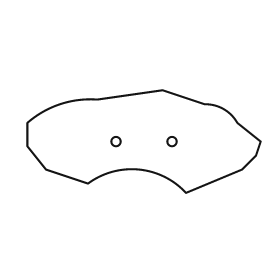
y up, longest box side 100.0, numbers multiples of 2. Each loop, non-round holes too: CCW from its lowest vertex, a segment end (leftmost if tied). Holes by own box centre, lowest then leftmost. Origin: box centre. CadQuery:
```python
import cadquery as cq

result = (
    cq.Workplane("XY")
    .moveTo(18.0, -22.0)
    .lineTo(42.0, -12.0)
    .lineTo(48.0, -6.0)
    .lineTo(50.0, 0.0)
    .lineTo(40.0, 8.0)
    .threePointArc((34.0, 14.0), (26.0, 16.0))
    .lineTo(8.0, 22.0)
    .lineTo(-20.0, 18.0)
    .threePointArc((-36.0, 16.0), (-50.0, 8.0))
    .lineTo(-50.0, -2.0)
    .lineTo(-42.0, -12.0)
    .lineTo(-24.0, -18.0)
    .threePointArc((-2.0, -12.0), (18.0, -22.0))
    .close()
    .moveTo(-12.0, 0.0)
    .circle(2.0)
    .moveTo(12.0, 0.0)
    .circle(2.0)
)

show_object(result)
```